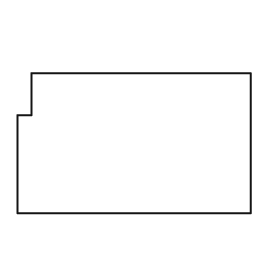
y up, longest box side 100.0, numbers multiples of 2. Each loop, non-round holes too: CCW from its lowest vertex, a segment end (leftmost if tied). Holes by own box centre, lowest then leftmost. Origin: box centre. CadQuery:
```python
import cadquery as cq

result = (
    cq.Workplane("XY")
    .moveTo(-50.0, -30.0)
    .lineTo(50.0, -30.0)
    .lineTo(50.0, 30.0)
    .lineTo(-44.0, 30.0)
    .lineTo(-44.0, 12.0)
    .lineTo(-50.0, 12.0)
    .close()
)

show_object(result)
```